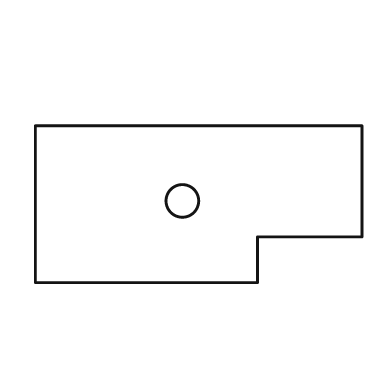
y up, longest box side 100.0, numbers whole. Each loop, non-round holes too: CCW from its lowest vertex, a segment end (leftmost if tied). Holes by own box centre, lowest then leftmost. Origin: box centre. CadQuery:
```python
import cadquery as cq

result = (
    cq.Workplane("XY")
    .moveTo(-50.0, -24.0)
    .lineTo(18.0, -24.0)
    .lineTo(18.0, -10.0)
    .lineTo(50.0, -10.0)
    .lineTo(50.0, 24.0)
    .lineTo(-50.0, 24.0)
    .close()
    .moveTo(-5.0, 1.0)
    .circle(5.0)
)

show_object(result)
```